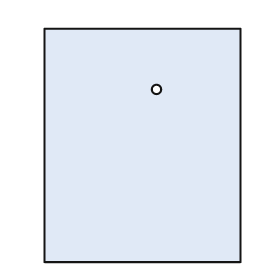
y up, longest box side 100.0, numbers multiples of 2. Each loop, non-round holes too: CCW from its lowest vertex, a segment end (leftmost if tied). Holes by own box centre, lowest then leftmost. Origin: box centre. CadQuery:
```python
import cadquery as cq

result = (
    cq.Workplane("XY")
    .moveTo(-42.0, -50.0)
    .lineTo(42.0, -50.0)
    .lineTo(42.0, 50.0)
    .lineTo(-42.0, 50.0)
    .close()
    .moveTo(6.0, 24.0)
    .circle(2.0)
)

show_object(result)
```